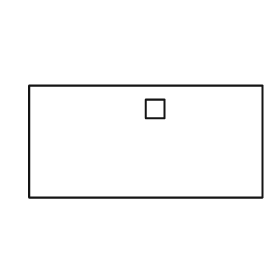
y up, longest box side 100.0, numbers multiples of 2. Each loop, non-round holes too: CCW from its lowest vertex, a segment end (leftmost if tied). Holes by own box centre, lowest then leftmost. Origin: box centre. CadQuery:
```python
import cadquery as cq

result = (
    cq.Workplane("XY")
    .moveTo(-50.0, -24.0)
    .lineTo(50.0, -24.0)
    .lineTo(50.0, 24.0)
    .lineTo(-50.0, 24.0)
    .close()
    .moveTo(0.0, 10.0)
    .lineTo(8.0, 10.0)
    .lineTo(8.0, 18.0)
    .lineTo(0.0, 18.0)
    .close()
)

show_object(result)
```